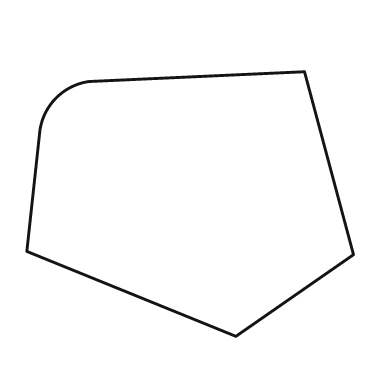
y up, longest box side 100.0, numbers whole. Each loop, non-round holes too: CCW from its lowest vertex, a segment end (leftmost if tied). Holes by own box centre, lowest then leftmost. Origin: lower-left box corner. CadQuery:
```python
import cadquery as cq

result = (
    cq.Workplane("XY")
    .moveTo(64.0, 0.0)
    .lineTo(100.0, 25.0)
    .lineTo(85.0, 81.0)
    .lineTo(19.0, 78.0)
    .threePointArc((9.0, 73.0), (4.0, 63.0))
    .lineTo(0.0, 26.0)
    .close()
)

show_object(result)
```